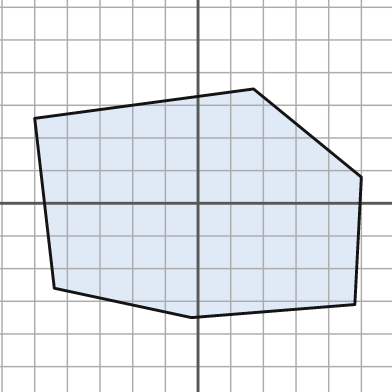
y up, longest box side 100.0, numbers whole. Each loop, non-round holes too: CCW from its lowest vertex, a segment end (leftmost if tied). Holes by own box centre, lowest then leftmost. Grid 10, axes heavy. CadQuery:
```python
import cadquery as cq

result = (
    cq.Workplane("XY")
    .moveTo(-2.0, -35.0)
    .lineTo(48.0, -31.0)
    .lineTo(50.0, 8.0)
    .lineTo(17.0, 35.0)
    .lineTo(-50.0, 26.0)
    .lineTo(-44.0, -26.0)
    .close()
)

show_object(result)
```